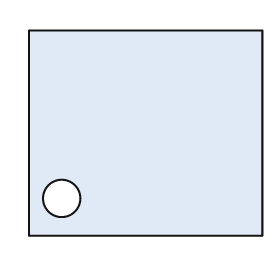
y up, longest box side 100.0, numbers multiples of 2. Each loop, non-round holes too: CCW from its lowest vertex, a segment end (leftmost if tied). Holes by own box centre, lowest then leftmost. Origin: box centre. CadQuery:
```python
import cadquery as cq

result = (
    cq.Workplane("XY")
    .moveTo(-50.0, -44.0)
    .lineTo(50.0, -44.0)
    .lineTo(50.0, 44.0)
    .lineTo(-50.0, 44.0)
    .close()
    .moveTo(-36.0, -28.0)
    .circle(8.0)
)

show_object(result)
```